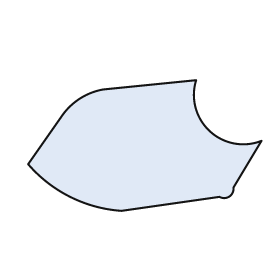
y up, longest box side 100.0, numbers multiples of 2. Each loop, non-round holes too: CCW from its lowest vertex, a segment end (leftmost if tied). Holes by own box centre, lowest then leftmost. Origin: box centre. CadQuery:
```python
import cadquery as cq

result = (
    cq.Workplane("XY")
    .moveTo(-10.0, -28.0)
    .lineTo(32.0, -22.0)
    .threePointArc((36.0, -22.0), (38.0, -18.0))
    .lineTo(50.0, 2.0)
    .threePointArc((28.0, 6.0), (22.0, 28.0))
    .lineTo(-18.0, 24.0)
    .threePointArc((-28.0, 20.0), (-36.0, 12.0))
    .lineTo(-50.0, -8.0)
    .threePointArc((-32.0, -22.0), (-10.0, -28.0))
    .close()
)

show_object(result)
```